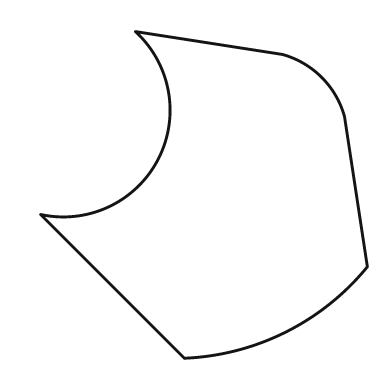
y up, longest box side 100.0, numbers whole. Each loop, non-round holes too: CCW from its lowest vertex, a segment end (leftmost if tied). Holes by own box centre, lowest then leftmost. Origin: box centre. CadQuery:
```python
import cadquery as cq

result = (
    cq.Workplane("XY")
    .moveTo(-6.0, -50.0)
    .threePointArc((25.0, -42.0), (50.0, -22.0))
    .lineTo(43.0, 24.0)
    .threePointArc((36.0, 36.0), (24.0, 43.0))
    .lineTo(-21.0, 50.0)
    .threePointArc((-14.0, 11.0), (-50.0, -6.0))
    .close()
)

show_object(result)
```